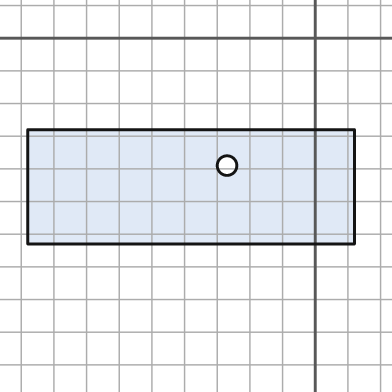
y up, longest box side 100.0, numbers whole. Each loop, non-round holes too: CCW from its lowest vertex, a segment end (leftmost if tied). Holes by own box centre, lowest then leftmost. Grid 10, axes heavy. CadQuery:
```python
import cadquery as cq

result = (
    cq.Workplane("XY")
    .moveTo(-88.0, -63.0)
    .lineTo(12.0, -63.0)
    .lineTo(12.0, -28.0)
    .lineTo(-88.0, -28.0)
    .close()
    .moveTo(-27.0, -39.0)
    .circle(3.0)
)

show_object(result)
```